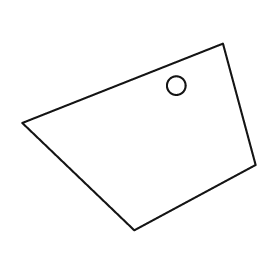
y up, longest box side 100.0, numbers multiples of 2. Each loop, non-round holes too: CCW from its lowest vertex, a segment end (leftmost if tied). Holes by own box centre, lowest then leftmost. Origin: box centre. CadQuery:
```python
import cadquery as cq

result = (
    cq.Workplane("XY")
    .moveTo(-2.0, -40.0)
    .lineTo(50.0, -12.0)
    .lineTo(36.0, 40.0)
    .lineTo(-50.0, 6.0)
    .close()
    .moveTo(16.0, 22.0)
    .circle(4.0)
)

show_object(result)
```